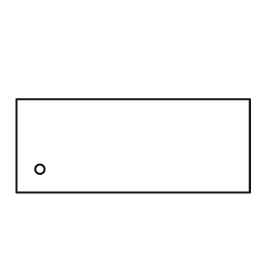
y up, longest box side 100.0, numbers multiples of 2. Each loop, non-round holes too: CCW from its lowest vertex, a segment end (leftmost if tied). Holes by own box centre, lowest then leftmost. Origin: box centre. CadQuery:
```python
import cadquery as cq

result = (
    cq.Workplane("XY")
    .moveTo(-50.0, -20.0)
    .lineTo(50.0, -20.0)
    .lineTo(50.0, 20.0)
    .lineTo(-50.0, 20.0)
    .close()
    .moveTo(-40.0, -10.0)
    .circle(2.0)
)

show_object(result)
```